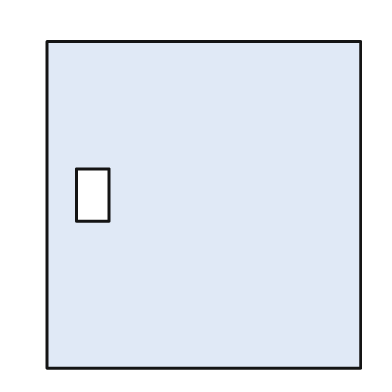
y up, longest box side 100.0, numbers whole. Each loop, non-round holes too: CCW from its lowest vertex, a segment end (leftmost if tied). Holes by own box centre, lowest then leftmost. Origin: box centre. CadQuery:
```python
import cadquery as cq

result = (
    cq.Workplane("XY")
    .moveTo(-48.0, -50.0)
    .lineTo(48.0, -50.0)
    .lineTo(48.0, 50.0)
    .lineTo(-48.0, 50.0)
    .close()
    .moveTo(-39.0, -5.0)
    .lineTo(-29.0, -5.0)
    .lineTo(-29.0, 11.0)
    .lineTo(-39.0, 11.0)
    .close()
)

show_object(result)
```